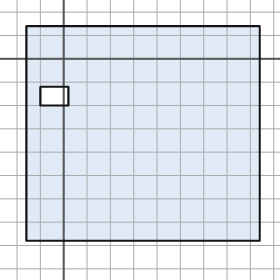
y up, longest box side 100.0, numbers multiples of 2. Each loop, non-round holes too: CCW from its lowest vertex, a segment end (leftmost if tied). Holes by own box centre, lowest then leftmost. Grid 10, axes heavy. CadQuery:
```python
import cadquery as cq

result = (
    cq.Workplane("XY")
    .moveTo(-16.0, -78.0)
    .lineTo(84.0, -78.0)
    .lineTo(84.0, 14.0)
    .lineTo(-16.0, 14.0)
    .close()
    .moveTo(-10.0, -20.0)
    .lineTo(2.0, -20.0)
    .lineTo(2.0, -12.0)
    .lineTo(-10.0, -12.0)
    .close()
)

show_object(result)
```